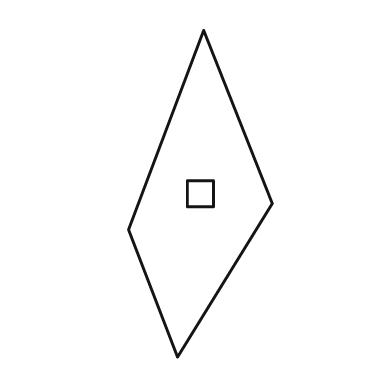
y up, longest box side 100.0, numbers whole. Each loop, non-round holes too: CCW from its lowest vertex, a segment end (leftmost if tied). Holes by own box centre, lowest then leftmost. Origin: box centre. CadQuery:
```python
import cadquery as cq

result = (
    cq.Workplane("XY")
    .moveTo(-7.0, -50.0)
    .lineTo(22.0, -3.0)
    .lineTo(1.0, 50.0)
    .lineTo(-22.0, -11.0)
    .close()
    .moveTo(-4.0, -4.0)
    .lineTo(4.0, -4.0)
    .lineTo(4.0, 4.0)
    .lineTo(-4.0, 4.0)
    .close()
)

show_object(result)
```